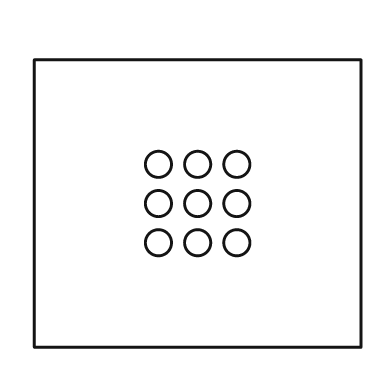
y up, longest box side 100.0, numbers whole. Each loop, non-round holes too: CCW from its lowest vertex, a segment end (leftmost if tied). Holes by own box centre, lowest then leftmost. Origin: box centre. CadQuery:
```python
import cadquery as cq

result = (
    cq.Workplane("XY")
    .moveTo(-50.0, -44.0)
    .lineTo(50.0, -44.0)
    .lineTo(50.0, 44.0)
    .lineTo(-50.0, 44.0)
    .close()
    .moveTo(-12.0, -12.0)
    .circle(4.0)
    .moveTo(0.0, -12.0)
    .circle(4.0)
    .moveTo(12.0, -12.0)
    .circle(4.0)
    .moveTo(-12.0, 0.0)
    .circle(4.0)
    .moveTo(0.0, 0.0)
    .circle(4.0)
    .moveTo(12.0, 0.0)
    .circle(4.0)
    .moveTo(-12.0, 12.0)
    .circle(4.0)
    .moveTo(0.0, 12.0)
    .circle(4.0)
    .moveTo(12.0, 12.0)
    .circle(4.0)
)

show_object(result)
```